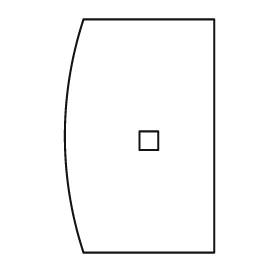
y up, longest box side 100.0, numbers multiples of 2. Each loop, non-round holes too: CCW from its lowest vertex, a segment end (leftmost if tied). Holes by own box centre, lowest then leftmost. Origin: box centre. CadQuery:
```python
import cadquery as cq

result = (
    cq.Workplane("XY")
    .moveTo(-24.0, -50.0)
    .lineTo(32.0, -50.0)
    .lineTo(32.0, 50.0)
    .lineTo(-24.0, 50.0)
    .threePointArc((-32.0, 0.0), (-24.0, -50.0))
    .close()
    .moveTo(0.0, -6.0)
    .lineTo(8.0, -6.0)
    .lineTo(8.0, 2.0)
    .lineTo(0.0, 2.0)
    .close()
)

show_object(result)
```